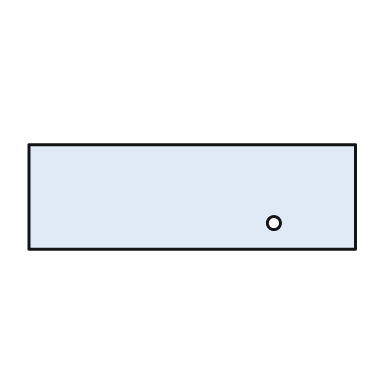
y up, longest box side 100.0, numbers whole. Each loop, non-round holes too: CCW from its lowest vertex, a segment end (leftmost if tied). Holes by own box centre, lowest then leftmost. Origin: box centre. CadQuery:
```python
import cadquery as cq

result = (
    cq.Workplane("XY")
    .moveTo(-50.0, -16.0)
    .lineTo(50.0, -16.0)
    .lineTo(50.0, 16.0)
    .lineTo(-50.0, 16.0)
    .close()
    .moveTo(25.0, -8.0)
    .circle(2.0)
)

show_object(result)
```